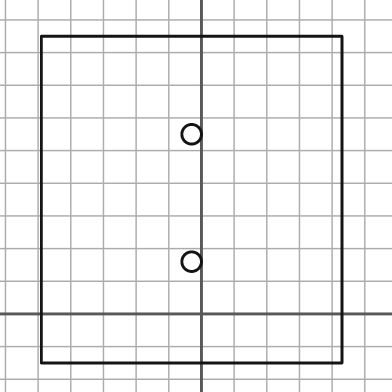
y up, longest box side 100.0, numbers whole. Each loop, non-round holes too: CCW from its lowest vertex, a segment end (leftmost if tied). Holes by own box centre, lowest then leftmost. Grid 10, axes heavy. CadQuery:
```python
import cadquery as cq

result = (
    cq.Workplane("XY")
    .moveTo(-49.0, -15.0)
    .lineTo(43.0, -15.0)
    .lineTo(43.0, 85.0)
    .lineTo(-49.0, 85.0)
    .close()
    .moveTo(-3.0, 16.0)
    .circle(3.0)
    .moveTo(-3.0, 55.0)
    .circle(3.0)
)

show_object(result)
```